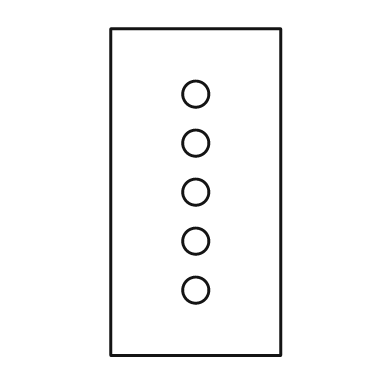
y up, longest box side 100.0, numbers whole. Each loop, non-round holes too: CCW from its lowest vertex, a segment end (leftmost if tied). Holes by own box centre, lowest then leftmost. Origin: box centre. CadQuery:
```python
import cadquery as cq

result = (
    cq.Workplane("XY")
    .moveTo(-26.0, -50.0)
    .lineTo(26.0, -50.0)
    .lineTo(26.0, 50.0)
    .lineTo(-26.0, 50.0)
    .close()
    .moveTo(0.0, -30.0)
    .circle(4.0)
    .moveTo(0.0, -15.0)
    .circle(4.0)
    .moveTo(0.0, 0.0)
    .circle(4.0)
    .moveTo(0.0, 15.0)
    .circle(4.0)
    .moveTo(0.0, 30.0)
    .circle(4.0)
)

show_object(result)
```